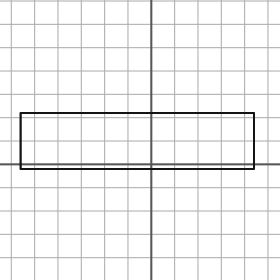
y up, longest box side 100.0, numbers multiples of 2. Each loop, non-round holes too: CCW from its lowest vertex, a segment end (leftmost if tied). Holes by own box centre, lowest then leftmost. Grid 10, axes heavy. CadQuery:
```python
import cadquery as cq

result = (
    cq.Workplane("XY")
    .moveTo(-56.0, -2.0)
    .lineTo(44.0, -2.0)
    .lineTo(44.0, 22.0)
    .lineTo(-56.0, 22.0)
    .close()
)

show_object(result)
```